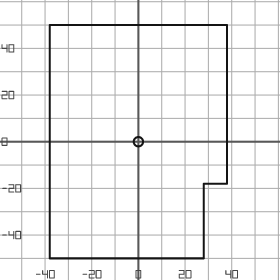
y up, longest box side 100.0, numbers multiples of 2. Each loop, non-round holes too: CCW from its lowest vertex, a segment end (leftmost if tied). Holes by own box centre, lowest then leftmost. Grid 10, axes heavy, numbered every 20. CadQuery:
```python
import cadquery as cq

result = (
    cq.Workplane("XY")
    .moveTo(-38.0, -50.0)
    .lineTo(28.0, -50.0)
    .lineTo(28.0, -18.0)
    .lineTo(38.0, -18.0)
    .lineTo(38.0, 50.0)
    .lineTo(-38.0, 50.0)
    .close()
    .moveTo(0.0, 0.0)
    .circle(2.0)
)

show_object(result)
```